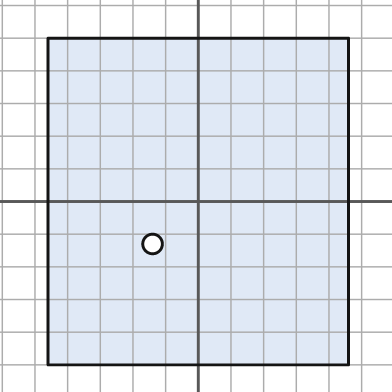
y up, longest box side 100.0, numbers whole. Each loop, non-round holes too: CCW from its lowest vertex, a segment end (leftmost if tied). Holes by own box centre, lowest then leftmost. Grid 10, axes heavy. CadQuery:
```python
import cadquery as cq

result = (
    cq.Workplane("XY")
    .moveTo(-46.0, -50.0)
    .lineTo(46.0, -50.0)
    .lineTo(46.0, 50.0)
    .lineTo(-46.0, 50.0)
    .close()
    .moveTo(-14.0, -13.0)
    .circle(3.0)
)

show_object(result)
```